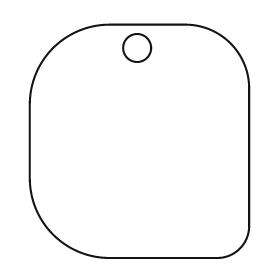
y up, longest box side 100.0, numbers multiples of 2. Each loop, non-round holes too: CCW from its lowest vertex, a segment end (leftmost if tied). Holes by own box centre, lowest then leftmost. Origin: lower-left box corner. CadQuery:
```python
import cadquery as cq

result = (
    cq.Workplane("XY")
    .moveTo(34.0, 0.0)
    .lineTo(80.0, 0.0)
    .threePointArc((90.0, 4.0), (94.0, 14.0))
    .lineTo(94.0, 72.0)
    .threePointArc((86.0, 92.0), (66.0, 100.0))
    .lineTo(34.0, 100.0)
    .threePointArc((10.0, 90.0), (0.0, 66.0))
    .lineTo(0.0, 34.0)
    .threePointArc((10.0, 10.0), (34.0, 0.0))
    .close()
    .moveTo(46.0, 90.0)
    .circle(6.0)
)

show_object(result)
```